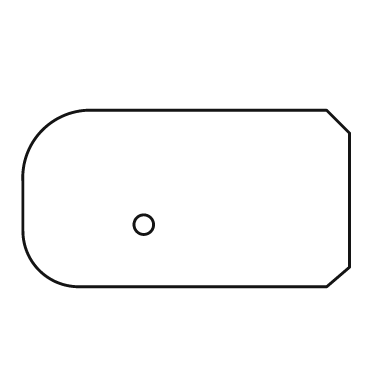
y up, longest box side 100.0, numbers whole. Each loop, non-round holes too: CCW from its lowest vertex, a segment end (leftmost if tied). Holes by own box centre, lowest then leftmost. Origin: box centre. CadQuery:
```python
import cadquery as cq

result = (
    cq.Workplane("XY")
    .moveTo(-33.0, -27.0)
    .lineTo(43.0, -27.0)
    .lineTo(50.0, -21.0)
    .lineTo(50.0, 20.0)
    .lineTo(43.0, 27.0)
    .lineTo(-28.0, 27.0)
    .threePointArc((-44.0, 21.0), (-50.0, 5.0))
    .lineTo(-50.0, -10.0)
    .threePointArc((-45.0, -22.0), (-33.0, -27.0))
    .close()
    .moveTo(-13.0, -8.0)
    .circle(3.0)
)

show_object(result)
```